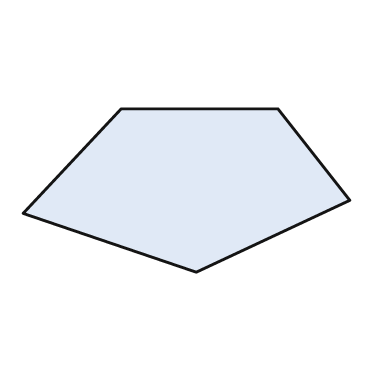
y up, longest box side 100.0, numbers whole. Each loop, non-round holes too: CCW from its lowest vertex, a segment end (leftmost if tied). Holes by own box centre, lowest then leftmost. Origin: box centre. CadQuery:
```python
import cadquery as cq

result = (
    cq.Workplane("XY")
    .moveTo(3.0, -25.0)
    .lineTo(50.0, -3.0)
    .lineTo(28.0, 25.0)
    .lineTo(-20.0, 25.0)
    .lineTo(-50.0, -7.0)
    .close()
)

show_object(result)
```